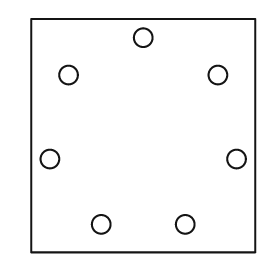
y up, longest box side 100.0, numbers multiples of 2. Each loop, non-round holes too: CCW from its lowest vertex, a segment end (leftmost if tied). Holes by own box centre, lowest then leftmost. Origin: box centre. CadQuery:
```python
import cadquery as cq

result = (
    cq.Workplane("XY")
    .moveTo(-48.0, -50.0)
    .lineTo(48.0, -50.0)
    .lineTo(48.0, 50.0)
    .lineTo(-48.0, 50.0)
    .close()
    .moveTo(-18.0, -38.0)
    .circle(4.0)
    .moveTo(18.0, -38.0)
    .circle(4.0)
    .moveTo(-40.0, -10.0)
    .circle(4.0)
    .moveTo(40.0, -10.0)
    .circle(4.0)
    .moveTo(-32.0, 26.0)
    .circle(4.0)
    .moveTo(32.0, 26.0)
    .circle(4.0)
    .moveTo(0.0, 42.0)
    .circle(4.0)
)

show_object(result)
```